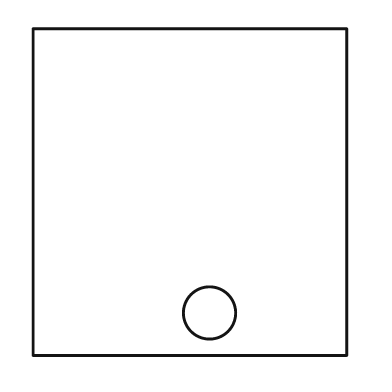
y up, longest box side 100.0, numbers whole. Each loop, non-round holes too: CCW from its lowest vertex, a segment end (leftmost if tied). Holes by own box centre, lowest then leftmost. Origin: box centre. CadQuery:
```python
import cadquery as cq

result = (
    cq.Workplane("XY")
    .moveTo(-48.0, -50.0)
    .lineTo(48.0, -50.0)
    .lineTo(48.0, 50.0)
    .lineTo(-48.0, 50.0)
    .close()
    .moveTo(6.0, -37.0)
    .circle(8.0)
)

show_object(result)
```